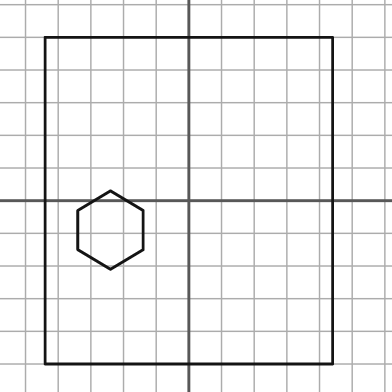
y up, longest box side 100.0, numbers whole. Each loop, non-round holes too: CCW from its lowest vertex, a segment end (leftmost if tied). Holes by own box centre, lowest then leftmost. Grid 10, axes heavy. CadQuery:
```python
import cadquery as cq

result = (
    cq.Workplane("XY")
    .moveTo(-44.0, -50.0)
    .lineTo(44.0, -50.0)
    .lineTo(44.0, 50.0)
    .lineTo(-44.0, 50.0)
    .close()
    .moveTo(-24.0, -21.0)
    .lineTo(-14.0, -15.0)
    .lineTo(-14.0, -3.0)
    .lineTo(-24.0, 3.0)
    .lineTo(-34.0, -3.0)
    .lineTo(-34.0, -15.0)
    .close()
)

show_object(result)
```